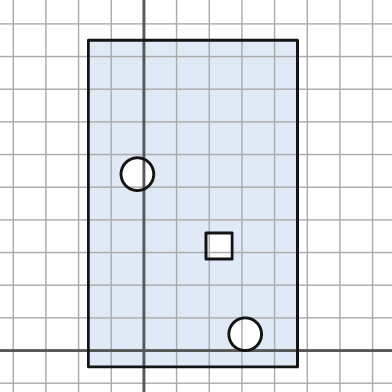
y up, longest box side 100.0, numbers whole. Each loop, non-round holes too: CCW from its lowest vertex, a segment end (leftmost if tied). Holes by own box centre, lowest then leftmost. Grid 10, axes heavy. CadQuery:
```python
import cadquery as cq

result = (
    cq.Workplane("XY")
    .moveTo(-17.0, -5.0)
    .lineTo(47.0, -5.0)
    .lineTo(47.0, 95.0)
    .lineTo(-17.0, 95.0)
    .close()
    .moveTo(31.0, 5.0)
    .circle(5.0)
    .moveTo(19.0, 28.0)
    .lineTo(27.0, 28.0)
    .lineTo(27.0, 36.0)
    .lineTo(19.0, 36.0)
    .close()
    .moveTo(-2.0, 54.0)
    .circle(5.0)
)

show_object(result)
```